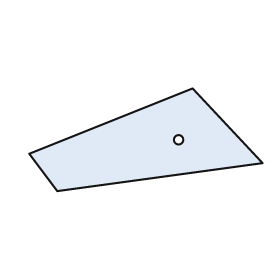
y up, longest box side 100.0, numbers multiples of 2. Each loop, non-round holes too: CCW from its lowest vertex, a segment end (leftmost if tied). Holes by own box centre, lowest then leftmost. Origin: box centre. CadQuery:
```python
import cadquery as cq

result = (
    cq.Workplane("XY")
    .moveTo(-38.0, -22.0)
    .lineTo(50.0, -10.0)
    .lineTo(20.0, 22.0)
    .lineTo(-50.0, -6.0)
    .close()
    .moveTo(14.0, 0.0)
    .circle(2.0)
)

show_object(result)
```